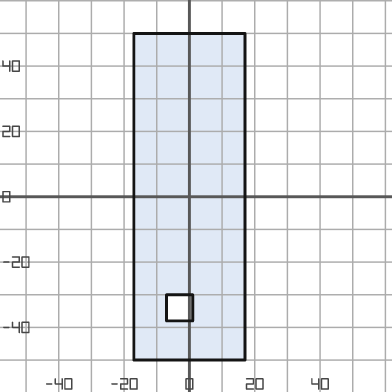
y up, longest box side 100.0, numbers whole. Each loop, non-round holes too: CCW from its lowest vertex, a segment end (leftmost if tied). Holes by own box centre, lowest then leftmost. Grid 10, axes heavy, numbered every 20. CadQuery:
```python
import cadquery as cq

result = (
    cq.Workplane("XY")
    .moveTo(-17.0, -50.0)
    .lineTo(17.0, -50.0)
    .lineTo(17.0, 50.0)
    .lineTo(-17.0, 50.0)
    .close()
    .moveTo(-7.0, -38.0)
    .lineTo(1.0, -38.0)
    .lineTo(1.0, -30.0)
    .lineTo(-7.0, -30.0)
    .close()
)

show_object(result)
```